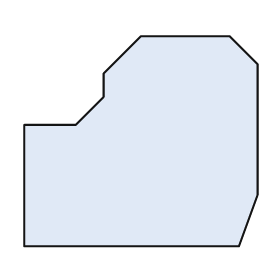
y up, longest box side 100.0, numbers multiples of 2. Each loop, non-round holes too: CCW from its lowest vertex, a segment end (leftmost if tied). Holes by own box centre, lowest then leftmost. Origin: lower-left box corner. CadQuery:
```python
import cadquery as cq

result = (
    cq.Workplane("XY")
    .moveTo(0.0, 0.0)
    .lineTo(92.0, 0.0)
    .lineTo(100.0, 22.0)
    .lineTo(100.0, 78.0)
    .lineTo(88.0, 90.0)
    .lineTo(50.0, 90.0)
    .lineTo(34.0, 74.0)
    .lineTo(34.0, 64.0)
    .lineTo(22.0, 52.0)
    .lineTo(0.0, 52.0)
    .close()
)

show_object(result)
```